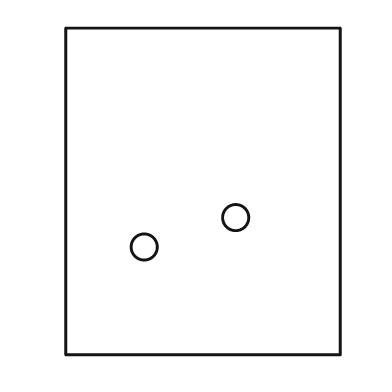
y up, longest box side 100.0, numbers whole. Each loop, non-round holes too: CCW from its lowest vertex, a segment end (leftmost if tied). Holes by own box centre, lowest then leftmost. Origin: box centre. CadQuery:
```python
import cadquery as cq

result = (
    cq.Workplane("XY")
    .moveTo(-42.0, -50.0)
    .lineTo(42.0, -50.0)
    .lineTo(42.0, 50.0)
    .lineTo(-42.0, 50.0)
    .close()
    .moveTo(-18.0, -17.0)
    .circle(4.0)
    .moveTo(10.0, -8.0)
    .circle(4.0)
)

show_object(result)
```